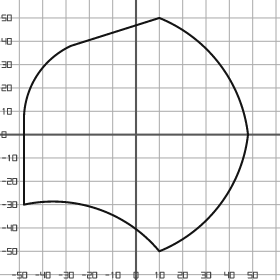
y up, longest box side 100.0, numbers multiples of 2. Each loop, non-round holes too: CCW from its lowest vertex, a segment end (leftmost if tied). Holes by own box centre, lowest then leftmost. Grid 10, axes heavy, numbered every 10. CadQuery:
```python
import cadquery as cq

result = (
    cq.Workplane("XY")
    .moveTo(10.0, -50.0)
    .threePointArc((36.0, -30.0), (48.0, 0.0))
    .threePointArc((36.0, 30.0), (10.0, 50.0))
    .lineTo(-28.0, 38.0)
    .threePointArc((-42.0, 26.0), (-48.0, 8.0))
    .lineTo(-48.0, -30.0)
    .threePointArc((-16.0, -32.0), (10.0, -50.0))
    .close()
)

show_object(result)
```